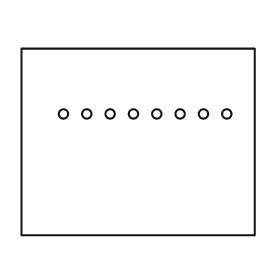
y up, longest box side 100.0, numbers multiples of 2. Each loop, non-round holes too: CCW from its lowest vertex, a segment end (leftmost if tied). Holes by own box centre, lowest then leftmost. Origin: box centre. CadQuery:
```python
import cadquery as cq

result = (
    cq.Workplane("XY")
    .moveTo(-50.0, -40.0)
    .lineTo(50.0, -40.0)
    .lineTo(50.0, 40.0)
    .lineTo(-50.0, 40.0)
    .close()
    .moveTo(-32.0, 12.0)
    .circle(2.0)
    .moveTo(-22.0, 12.0)
    .circle(2.0)
    .moveTo(-12.0, 12.0)
    .circle(2.0)
    .moveTo(-2.0, 12.0)
    .circle(2.0)
    .moveTo(8.0, 12.0)
    .circle(2.0)
    .moveTo(18.0, 12.0)
    .circle(2.0)
    .moveTo(28.0, 12.0)
    .circle(2.0)
    .moveTo(38.0, 12.0)
    .circle(2.0)
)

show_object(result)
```